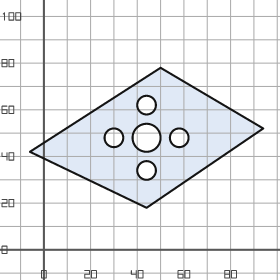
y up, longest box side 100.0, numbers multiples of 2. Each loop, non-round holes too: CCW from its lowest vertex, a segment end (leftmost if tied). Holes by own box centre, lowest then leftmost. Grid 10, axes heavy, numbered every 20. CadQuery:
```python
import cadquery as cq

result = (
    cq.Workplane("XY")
    .moveTo(44.0, 18.0)
    .lineTo(94.0, 52.0)
    .lineTo(50.0, 78.0)
    .lineTo(-6.0, 42.0)
    .close()
    .moveTo(44.0, 34.0)
    .circle(4.0)
    .moveTo(30.0, 48.0)
    .circle(4.0)
    .moveTo(44.0, 48.0)
    .circle(6.0)
    .moveTo(58.0, 48.0)
    .circle(4.0)
    .moveTo(44.0, 62.0)
    .circle(4.0)
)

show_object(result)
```